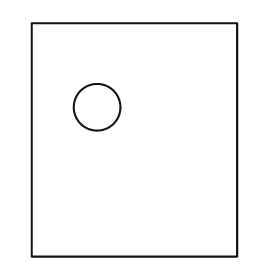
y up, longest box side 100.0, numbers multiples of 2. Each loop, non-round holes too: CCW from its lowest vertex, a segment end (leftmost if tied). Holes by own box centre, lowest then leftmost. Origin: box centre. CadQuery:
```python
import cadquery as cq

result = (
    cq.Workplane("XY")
    .moveTo(-44.0, -50.0)
    .lineTo(44.0, -50.0)
    .lineTo(44.0, 50.0)
    .lineTo(-44.0, 50.0)
    .close()
    .moveTo(-16.0, 14.0)
    .circle(10.0)
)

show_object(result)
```